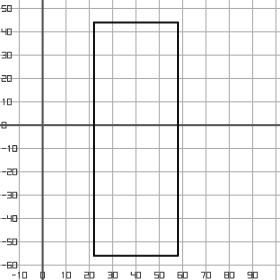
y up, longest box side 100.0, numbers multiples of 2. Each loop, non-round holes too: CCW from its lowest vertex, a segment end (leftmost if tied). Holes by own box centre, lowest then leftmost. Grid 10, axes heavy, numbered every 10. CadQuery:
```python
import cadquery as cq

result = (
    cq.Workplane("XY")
    .moveTo(22.0, -56.0)
    .lineTo(58.0, -56.0)
    .lineTo(58.0, 44.0)
    .lineTo(22.0, 44.0)
    .close()
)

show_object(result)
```